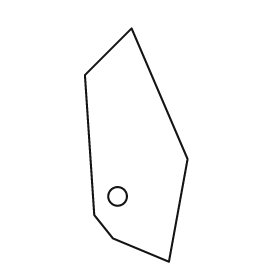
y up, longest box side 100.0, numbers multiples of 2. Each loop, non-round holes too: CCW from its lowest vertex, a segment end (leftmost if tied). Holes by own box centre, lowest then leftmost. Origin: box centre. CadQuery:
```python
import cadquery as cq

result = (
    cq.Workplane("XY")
    .moveTo(14.0, -50.0)
    .lineTo(22.0, -6.0)
    .lineTo(-2.0, 50.0)
    .lineTo(-22.0, 30.0)
    .lineTo(-18.0, -30.0)
    .lineTo(-10.0, -40.0)
    .close()
    .moveTo(-8.0, -22.0)
    .circle(4.0)
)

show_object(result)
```